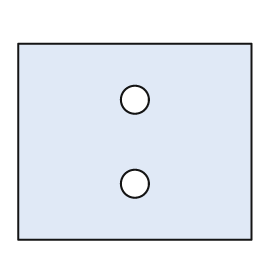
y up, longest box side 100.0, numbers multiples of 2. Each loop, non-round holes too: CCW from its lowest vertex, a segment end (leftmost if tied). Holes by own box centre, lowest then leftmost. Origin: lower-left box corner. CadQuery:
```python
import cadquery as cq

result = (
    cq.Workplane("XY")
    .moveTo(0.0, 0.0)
    .lineTo(100.0, 0.0)
    .lineTo(100.0, 84.0)
    .lineTo(0.0, 84.0)
    .close()
    .moveTo(50.0, 24.0)
    .circle(6.0)
    .moveTo(50.0, 60.0)
    .circle(6.0)
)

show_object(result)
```